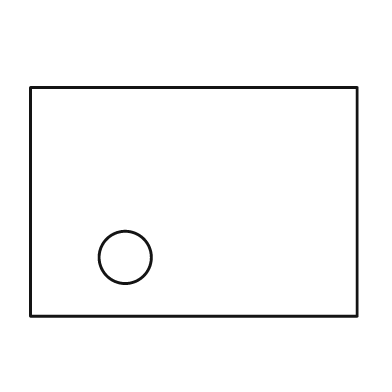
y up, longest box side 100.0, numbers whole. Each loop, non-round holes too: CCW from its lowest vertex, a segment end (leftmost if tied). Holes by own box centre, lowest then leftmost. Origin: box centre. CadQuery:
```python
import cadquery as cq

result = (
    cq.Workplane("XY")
    .moveTo(-50.0, -35.0)
    .lineTo(50.0, -35.0)
    .lineTo(50.0, 35.0)
    .lineTo(-50.0, 35.0)
    .close()
    .moveTo(-21.0, -17.0)
    .circle(8.0)
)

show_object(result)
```